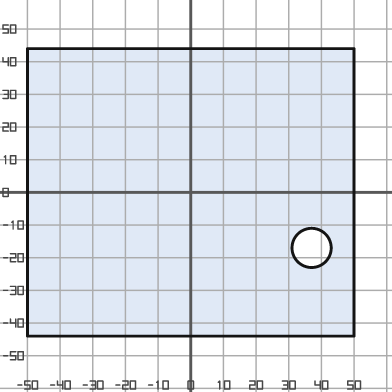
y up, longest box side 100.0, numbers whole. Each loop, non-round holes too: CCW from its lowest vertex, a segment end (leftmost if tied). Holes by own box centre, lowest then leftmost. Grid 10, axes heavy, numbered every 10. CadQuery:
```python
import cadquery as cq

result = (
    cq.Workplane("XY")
    .moveTo(-50.0, -44.0)
    .lineTo(50.0, -44.0)
    .lineTo(50.0, 44.0)
    .lineTo(-50.0, 44.0)
    .close()
    .moveTo(37.0, -17.0)
    .circle(6.0)
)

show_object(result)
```